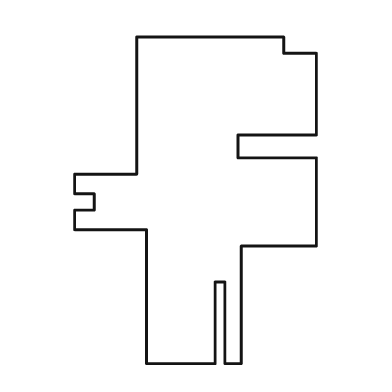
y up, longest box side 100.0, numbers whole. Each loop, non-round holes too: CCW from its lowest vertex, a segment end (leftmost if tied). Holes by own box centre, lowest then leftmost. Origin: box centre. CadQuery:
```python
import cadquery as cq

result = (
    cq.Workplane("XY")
    .moveTo(-15.0, -50.0)
    .lineTo(6.0, -50.0)
    .lineTo(6.0, -25.0)
    .lineTo(9.0, -25.0)
    .lineTo(9.0, -50.0)
    .lineTo(14.0, -50.0)
    .lineTo(14.0, -14.0)
    .lineTo(37.0, -14.0)
    .lineTo(37.0, 13.0)
    .lineTo(13.0, 13.0)
    .lineTo(13.0, 20.0)
    .lineTo(37.0, 20.0)
    .lineTo(37.0, 45.0)
    .lineTo(27.0, 45.0)
    .lineTo(27.0, 50.0)
    .lineTo(-18.0, 50.0)
    .lineTo(-18.0, 8.0)
    .lineTo(-37.0, 8.0)
    .lineTo(-37.0, 2.0)
    .lineTo(-31.0, 2.0)
    .lineTo(-31.0, -3.0)
    .lineTo(-37.0, -3.0)
    .lineTo(-37.0, -9.0)
    .lineTo(-15.0, -9.0)
    .close()
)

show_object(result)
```